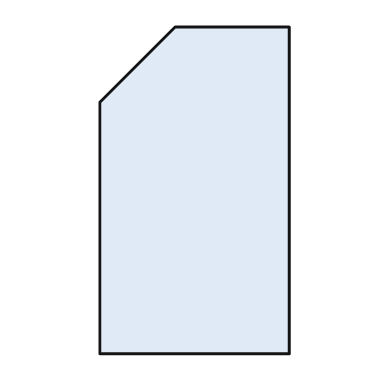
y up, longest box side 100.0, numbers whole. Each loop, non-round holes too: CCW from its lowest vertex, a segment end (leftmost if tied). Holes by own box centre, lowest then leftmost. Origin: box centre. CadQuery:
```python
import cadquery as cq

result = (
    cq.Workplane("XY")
    .moveTo(-29.0, -50.0)
    .lineTo(29.0, -50.0)
    .lineTo(29.0, 50.0)
    .lineTo(-6.0, 50.0)
    .lineTo(-29.0, 27.0)
    .close()
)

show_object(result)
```